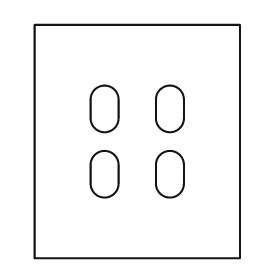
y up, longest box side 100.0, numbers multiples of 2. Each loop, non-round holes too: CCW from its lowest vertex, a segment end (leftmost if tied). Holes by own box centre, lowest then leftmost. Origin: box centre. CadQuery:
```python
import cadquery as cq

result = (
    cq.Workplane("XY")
    .moveTo(-44.0, -50.0)
    .lineTo(44.0, -50.0)
    .lineTo(44.0, 50.0)
    .lineTo(-44.0, 50.0)
    .close()
    .moveTo(-20.0, -18.0)
    .threePointArc((-14.0, -24.0), (-8.0, -18.0))
    .lineTo(-8.0, -10.0)
    .threePointArc((-14.0, -4.0), (-20.0, -10.0))
    .close()
    .moveTo(8.0, -18.0)
    .threePointArc((14.0, -24.0), (20.0, -18.0))
    .lineTo(20.0, -10.0)
    .threePointArc((14.0, -4.0), (8.0, -10.0))
    .close()
    .moveTo(-20.0, 10.0)
    .threePointArc((-14.0, 4.0), (-8.0, 10.0))
    .lineTo(-8.0, 18.0)
    .threePointArc((-14.0, 24.0), (-20.0, 18.0))
    .close()
    .moveTo(8.0, 10.0)
    .threePointArc((14.0, 4.0), (20.0, 10.0))
    .lineTo(20.0, 18.0)
    .threePointArc((14.0, 24.0), (8.0, 18.0))
    .close()
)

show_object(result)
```